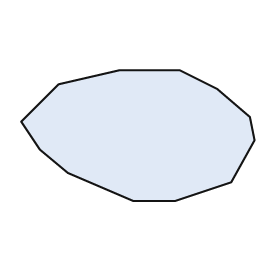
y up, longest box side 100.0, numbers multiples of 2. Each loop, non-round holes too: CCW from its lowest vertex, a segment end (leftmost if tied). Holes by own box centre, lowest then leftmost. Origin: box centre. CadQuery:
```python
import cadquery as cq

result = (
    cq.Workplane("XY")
    .moveTo(-2.0, -28.0)
    .lineTo(16.0, -28.0)
    .lineTo(40.0, -20.0)
    .lineTo(50.0, -2.0)
    .lineTo(48.0, 8.0)
    .lineTo(34.0, 20.0)
    .lineTo(18.0, 28.0)
    .lineTo(-8.0, 28.0)
    .lineTo(-34.0, 22.0)
    .lineTo(-50.0, 6.0)
    .lineTo(-42.0, -6.0)
    .lineTo(-30.0, -16.0)
    .close()
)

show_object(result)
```